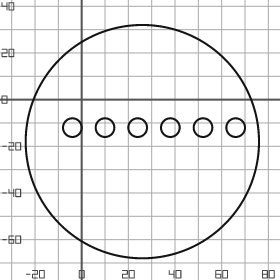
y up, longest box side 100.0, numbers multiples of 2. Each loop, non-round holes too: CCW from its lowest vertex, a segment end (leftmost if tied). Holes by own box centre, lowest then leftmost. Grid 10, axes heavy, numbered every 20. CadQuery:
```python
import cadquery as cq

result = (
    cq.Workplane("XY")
    .moveTo(26.0, -18.0)
    .circle(50.0)
    .moveTo(-4.0, -12.0)
    .circle(4.0)
    .moveTo(10.0, -12.0)
    .circle(4.0)
    .moveTo(24.0, -12.0)
    .circle(4.0)
    .moveTo(38.0, -12.0)
    .circle(4.0)
    .moveTo(52.0, -12.0)
    .circle(4.0)
    .moveTo(66.0, -12.0)
    .circle(4.0)
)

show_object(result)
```